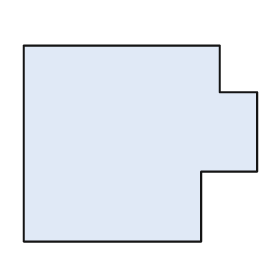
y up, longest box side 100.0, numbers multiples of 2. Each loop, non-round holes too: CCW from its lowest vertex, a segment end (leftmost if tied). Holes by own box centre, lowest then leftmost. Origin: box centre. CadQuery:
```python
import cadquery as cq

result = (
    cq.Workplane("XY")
    .moveTo(-50.0, -42.0)
    .lineTo(26.0, -42.0)
    .lineTo(26.0, -12.0)
    .lineTo(50.0, -12.0)
    .lineTo(50.0, 22.0)
    .lineTo(34.0, 22.0)
    .lineTo(34.0, 42.0)
    .lineTo(-50.0, 42.0)
    .close()
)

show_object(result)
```